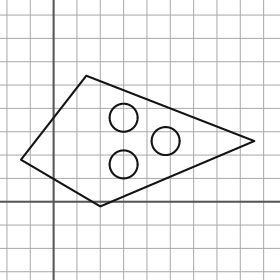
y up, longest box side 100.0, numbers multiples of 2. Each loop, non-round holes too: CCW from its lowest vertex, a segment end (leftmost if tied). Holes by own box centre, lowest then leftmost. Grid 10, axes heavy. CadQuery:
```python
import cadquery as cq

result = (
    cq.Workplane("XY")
    .moveTo(20.0, -2.0)
    .lineTo(86.0, 26.0)
    .lineTo(14.0, 54.0)
    .lineTo(-14.0, 18.0)
    .close()
    .moveTo(30.0, 16.0)
    .circle(6.0)
    .moveTo(48.0, 26.0)
    .circle(6.0)
    .moveTo(30.0, 36.0)
    .circle(6.0)
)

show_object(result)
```